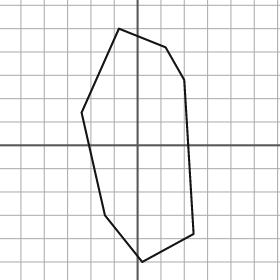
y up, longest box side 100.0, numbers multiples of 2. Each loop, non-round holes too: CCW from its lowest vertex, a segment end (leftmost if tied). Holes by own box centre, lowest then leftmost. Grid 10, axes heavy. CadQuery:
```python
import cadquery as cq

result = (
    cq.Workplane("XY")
    .moveTo(2.0, -50.0)
    .lineTo(24.0, -38.0)
    .lineTo(20.0, 28.0)
    .lineTo(12.0, 42.0)
    .lineTo(-8.0, 50.0)
    .lineTo(-24.0, 14.0)
    .lineTo(-14.0, -30.0)
    .close()
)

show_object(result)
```